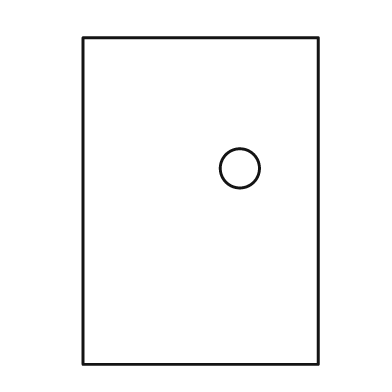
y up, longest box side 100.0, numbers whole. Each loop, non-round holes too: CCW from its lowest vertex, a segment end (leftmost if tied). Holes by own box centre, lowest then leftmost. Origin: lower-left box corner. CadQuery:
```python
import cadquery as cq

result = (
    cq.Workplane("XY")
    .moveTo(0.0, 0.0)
    .lineTo(72.0, 0.0)
    .lineTo(72.0, 100.0)
    .lineTo(0.0, 100.0)
    .close()
    .moveTo(48.0, 60.0)
    .circle(6.0)
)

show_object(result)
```